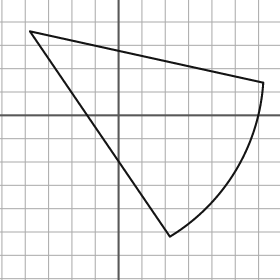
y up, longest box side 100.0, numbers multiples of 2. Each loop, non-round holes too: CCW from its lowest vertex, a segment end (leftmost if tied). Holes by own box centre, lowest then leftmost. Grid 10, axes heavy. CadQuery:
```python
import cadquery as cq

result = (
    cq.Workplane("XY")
    .moveTo(22.0, -52.0)
    .threePointArc((50.0, -24.0), (62.0, 14.0))
    .lineTo(-38.0, 36.0)
    .close()
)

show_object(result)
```